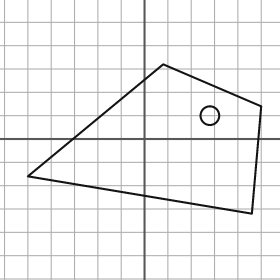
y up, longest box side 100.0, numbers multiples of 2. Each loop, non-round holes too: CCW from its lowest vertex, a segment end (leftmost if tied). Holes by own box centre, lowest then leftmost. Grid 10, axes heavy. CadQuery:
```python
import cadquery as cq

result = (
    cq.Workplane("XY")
    .moveTo(46.0, -32.0)
    .lineTo(50.0, 14.0)
    .lineTo(8.0, 32.0)
    .lineTo(-50.0, -16.0)
    .close()
    .moveTo(28.0, 10.0)
    .circle(4.0)
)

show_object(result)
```